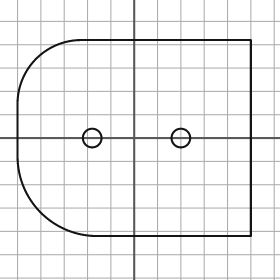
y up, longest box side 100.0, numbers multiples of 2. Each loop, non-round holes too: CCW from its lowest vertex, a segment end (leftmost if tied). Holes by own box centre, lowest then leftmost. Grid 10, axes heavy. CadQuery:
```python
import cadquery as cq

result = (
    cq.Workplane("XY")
    .moveTo(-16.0, -42.0)
    .lineTo(50.0, -42.0)
    .lineTo(50.0, 42.0)
    .lineTo(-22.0, 42.0)
    .threePointArc((-42.0, 34.0), (-50.0, 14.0))
    .lineTo(-50.0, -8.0)
    .threePointArc((-40.0, -32.0), (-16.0, -42.0))
    .close()
    .moveTo(-18.0, 0.0)
    .circle(4.0)
    .moveTo(20.0, 0.0)
    .circle(4.0)
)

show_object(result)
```